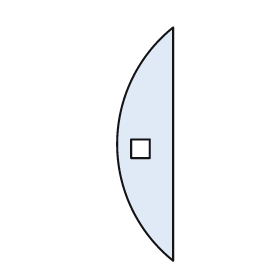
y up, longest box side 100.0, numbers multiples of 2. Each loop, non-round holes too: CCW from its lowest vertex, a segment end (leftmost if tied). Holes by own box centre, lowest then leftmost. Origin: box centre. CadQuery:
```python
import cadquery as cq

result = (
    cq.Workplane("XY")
    .moveTo(12.0, -50.0)
    .lineTo(12.0, 50.0)
    .threePointArc((-12.0, 0.0), (12.0, -50.0))
    .close()
    .moveTo(-6.0, -6.0)
    .lineTo(2.0, -6.0)
    .lineTo(2.0, 2.0)
    .lineTo(-6.0, 2.0)
    .close()
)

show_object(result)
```